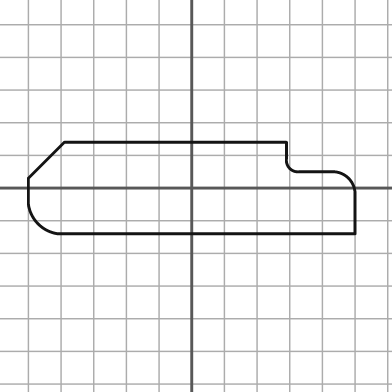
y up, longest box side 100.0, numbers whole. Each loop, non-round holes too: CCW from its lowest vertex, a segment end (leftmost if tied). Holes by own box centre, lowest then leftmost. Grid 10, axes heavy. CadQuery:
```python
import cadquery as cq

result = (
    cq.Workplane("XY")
    .moveTo(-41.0, -14.0)
    .lineTo(50.0, -14.0)
    .lineTo(50.0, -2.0)
    .threePointArc((48.0, 3.0), (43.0, 5.0))
    .lineTo(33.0, 5.0)
    .threePointArc((30.0, 6.0), (29.0, 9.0))
    .lineTo(29.0, 14.0)
    .lineTo(-39.0, 14.0)
    .lineTo(-50.0, 3.0)
    .lineTo(-50.0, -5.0)
    .threePointArc((-47.0, -11.0), (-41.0, -14.0))
    .close()
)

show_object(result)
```